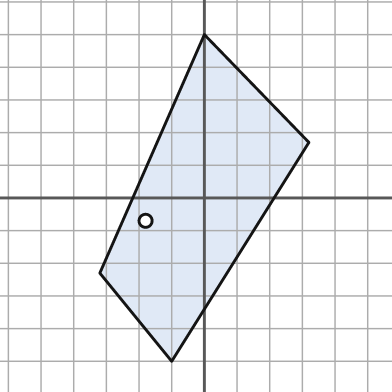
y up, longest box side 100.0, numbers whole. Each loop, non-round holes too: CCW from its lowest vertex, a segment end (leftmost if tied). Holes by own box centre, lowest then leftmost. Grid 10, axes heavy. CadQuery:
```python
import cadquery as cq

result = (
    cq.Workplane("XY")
    .moveTo(-10.0, -50.0)
    .lineTo(32.0, 17.0)
    .lineTo(0.0, 50.0)
    .lineTo(-32.0, -23.0)
    .close()
    .moveTo(-18.0, -7.0)
    .circle(2.0)
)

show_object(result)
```